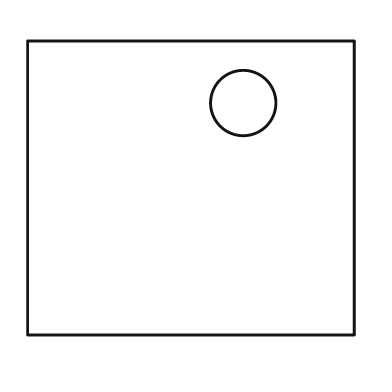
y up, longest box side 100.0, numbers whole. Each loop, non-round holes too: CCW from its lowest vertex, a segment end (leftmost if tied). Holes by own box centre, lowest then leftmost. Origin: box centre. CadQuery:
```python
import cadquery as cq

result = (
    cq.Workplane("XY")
    .moveTo(-50.0, -45.0)
    .lineTo(50.0, -45.0)
    .lineTo(50.0, 45.0)
    .lineTo(-50.0, 45.0)
    .close()
    .moveTo(16.0, 26.0)
    .circle(10.0)
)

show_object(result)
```